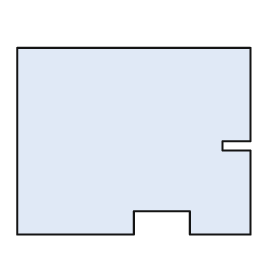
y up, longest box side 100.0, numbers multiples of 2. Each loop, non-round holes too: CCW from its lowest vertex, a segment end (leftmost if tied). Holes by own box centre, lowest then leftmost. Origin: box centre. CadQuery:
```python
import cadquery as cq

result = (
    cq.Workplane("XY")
    .moveTo(-50.0, -40.0)
    .lineTo(0.0, -40.0)
    .lineTo(0.0, -30.0)
    .lineTo(24.0, -30.0)
    .lineTo(24.0, -40.0)
    .lineTo(50.0, -40.0)
    .lineTo(50.0, -4.0)
    .lineTo(38.0, -4.0)
    .lineTo(38.0, 0.0)
    .lineTo(50.0, 0.0)
    .lineTo(50.0, 40.0)
    .lineTo(-50.0, 40.0)
    .close()
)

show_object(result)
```